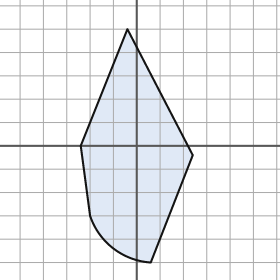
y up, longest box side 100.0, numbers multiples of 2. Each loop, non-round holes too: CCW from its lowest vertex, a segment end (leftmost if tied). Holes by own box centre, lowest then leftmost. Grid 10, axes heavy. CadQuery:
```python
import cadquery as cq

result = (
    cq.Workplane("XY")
    .moveTo(6.0, -50.0)
    .lineTo(24.0, -4.0)
    .lineTo(-4.0, 50.0)
    .lineTo(-24.0, 0.0)
    .lineTo(-20.0, -30.0)
    .threePointArc((-10.0, -44.0), (6.0, -50.0))
    .close()
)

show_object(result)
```